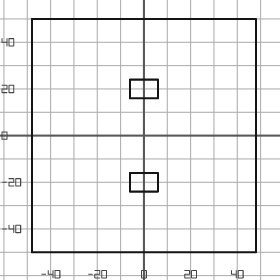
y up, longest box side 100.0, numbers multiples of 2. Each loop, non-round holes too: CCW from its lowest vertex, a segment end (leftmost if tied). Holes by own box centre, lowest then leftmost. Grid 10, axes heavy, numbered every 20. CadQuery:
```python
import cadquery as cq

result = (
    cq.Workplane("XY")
    .moveTo(-48.0, -50.0)
    .lineTo(48.0, -50.0)
    .lineTo(48.0, 50.0)
    .lineTo(-48.0, 50.0)
    .close()
    .moveTo(-6.0, -24.0)
    .lineTo(6.0, -24.0)
    .lineTo(6.0, -16.0)
    .lineTo(-6.0, -16.0)
    .close()
    .moveTo(-6.0, 16.0)
    .lineTo(6.0, 16.0)
    .lineTo(6.0, 24.0)
    .lineTo(-6.0, 24.0)
    .close()
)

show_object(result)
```